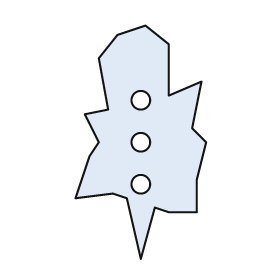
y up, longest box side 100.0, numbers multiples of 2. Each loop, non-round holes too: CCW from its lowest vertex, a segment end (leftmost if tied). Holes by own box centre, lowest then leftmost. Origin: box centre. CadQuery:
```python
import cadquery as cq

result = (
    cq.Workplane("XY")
    .moveTo(0.0, -50.0)
    .lineTo(6.0, -28.0)
    .lineTo(12.0, -30.0)
    .lineTo(24.0, -30.0)
    .lineTo(24.0, -16.0)
    .lineTo(28.0, 0.0)
    .lineTo(22.0, 6.0)
    .lineTo(26.0, 26.0)
    .lineTo(12.0, 20.0)
    .lineTo(12.0, 42.0)
    .lineTo(2.0, 50.0)
    .lineTo(-10.0, 46.0)
    .lineTo(-18.0, 36.0)
    .lineTo(-14.0, 14.0)
    .lineTo(-24.0, 12.0)
    .lineTo(-18.0, 0.0)
    .lineTo(-22.0, -6.0)
    .lineTo(-28.0, -24.0)
    .lineTo(-12.0, -22.0)
    .lineTo(-6.0, -24.0)
    .close()
    .moveTo(0.0, -18.0)
    .circle(4.0)
    .moveTo(0.0, 0.0)
    .circle(4.0)
    .moveTo(0.0, 18.0)
    .circle(4.0)
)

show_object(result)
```